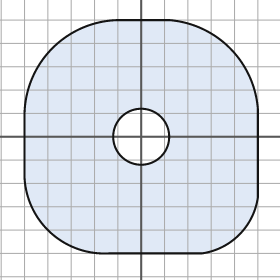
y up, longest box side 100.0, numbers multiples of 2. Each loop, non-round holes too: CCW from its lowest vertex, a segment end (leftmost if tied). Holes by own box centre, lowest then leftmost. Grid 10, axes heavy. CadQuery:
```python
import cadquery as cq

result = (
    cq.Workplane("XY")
    .moveTo(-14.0, -50.0)
    .lineTo(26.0, -50.0)
    .threePointArc((42.0, -42.0), (50.0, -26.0))
    .lineTo(50.0, 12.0)
    .threePointArc((38.0, 38.0), (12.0, 50.0))
    .lineTo(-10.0, 50.0)
    .threePointArc((-38.0, 38.0), (-50.0, 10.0))
    .lineTo(-50.0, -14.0)
    .threePointArc((-40.0, -40.0), (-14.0, -50.0))
    .close()
    .moveTo(0.0, 0.0)
    .circle(12.0)
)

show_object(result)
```